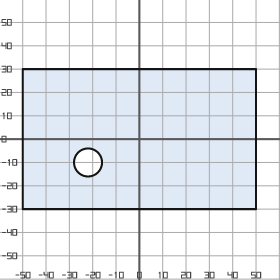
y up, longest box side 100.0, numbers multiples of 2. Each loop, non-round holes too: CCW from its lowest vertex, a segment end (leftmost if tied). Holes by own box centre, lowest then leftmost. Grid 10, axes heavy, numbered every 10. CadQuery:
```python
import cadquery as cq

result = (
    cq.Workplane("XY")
    .moveTo(-50.0, -30.0)
    .lineTo(50.0, -30.0)
    .lineTo(50.0, 30.0)
    .lineTo(-50.0, 30.0)
    .close()
    .moveTo(-22.0, -10.0)
    .circle(6.0)
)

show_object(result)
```